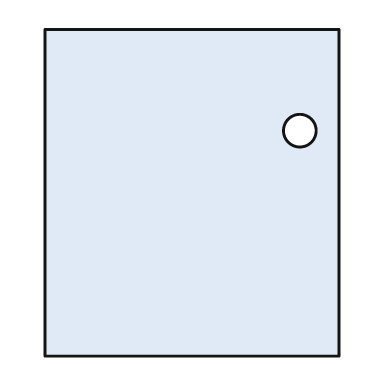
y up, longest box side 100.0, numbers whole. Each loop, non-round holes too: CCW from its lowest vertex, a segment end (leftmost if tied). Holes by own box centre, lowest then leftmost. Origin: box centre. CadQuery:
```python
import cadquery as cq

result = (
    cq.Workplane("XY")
    .moveTo(-45.0, -50.0)
    .lineTo(45.0, -50.0)
    .lineTo(45.0, 50.0)
    .lineTo(-45.0, 50.0)
    .close()
    .moveTo(33.0, 19.0)
    .circle(5.0)
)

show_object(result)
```